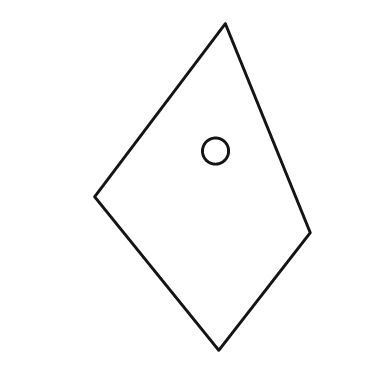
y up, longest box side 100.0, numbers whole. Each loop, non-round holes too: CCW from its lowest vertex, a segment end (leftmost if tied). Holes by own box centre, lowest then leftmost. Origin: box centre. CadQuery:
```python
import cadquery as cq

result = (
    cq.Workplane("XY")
    .moveTo(5.0, -50.0)
    .lineTo(33.0, -14.0)
    .lineTo(7.0, 50.0)
    .lineTo(-33.0, -3.0)
    .close()
    .moveTo(4.0, 11.0)
    .circle(4.0)
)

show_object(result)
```